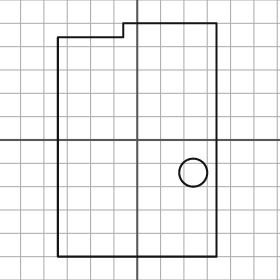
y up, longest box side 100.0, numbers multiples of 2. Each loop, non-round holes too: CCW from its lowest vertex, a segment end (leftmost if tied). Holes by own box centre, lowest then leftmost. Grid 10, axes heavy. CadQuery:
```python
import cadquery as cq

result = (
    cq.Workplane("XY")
    .moveTo(-34.0, -50.0)
    .lineTo(34.0, -50.0)
    .lineTo(34.0, 50.0)
    .lineTo(-6.0, 50.0)
    .lineTo(-6.0, 44.0)
    .lineTo(-34.0, 44.0)
    .close()
    .moveTo(24.0, -14.0)
    .circle(6.0)
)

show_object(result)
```